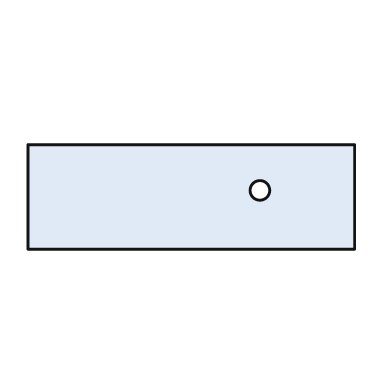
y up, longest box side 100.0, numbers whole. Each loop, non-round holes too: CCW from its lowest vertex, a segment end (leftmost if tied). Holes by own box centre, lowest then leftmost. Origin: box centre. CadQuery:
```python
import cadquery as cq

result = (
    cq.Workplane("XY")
    .moveTo(-50.0, -16.0)
    .lineTo(50.0, -16.0)
    .lineTo(50.0, 16.0)
    .lineTo(-50.0, 16.0)
    .close()
    .moveTo(21.0, 2.0)
    .circle(3.0)
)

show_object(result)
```